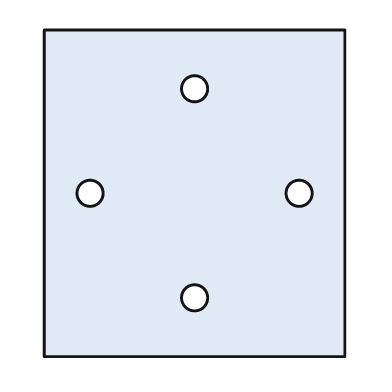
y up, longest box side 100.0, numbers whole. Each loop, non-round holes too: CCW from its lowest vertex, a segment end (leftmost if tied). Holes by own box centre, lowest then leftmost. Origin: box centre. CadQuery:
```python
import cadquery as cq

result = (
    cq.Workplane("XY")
    .moveTo(-46.0, -50.0)
    .lineTo(46.0, -50.0)
    .lineTo(46.0, 50.0)
    .lineTo(-46.0, 50.0)
    .close()
    .moveTo(0.0, -32.0)
    .circle(4.0)
    .moveTo(-32.0, 0.0)
    .circle(4.0)
    .moveTo(32.0, 0.0)
    .circle(4.0)
    .moveTo(0.0, 32.0)
    .circle(4.0)
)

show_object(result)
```